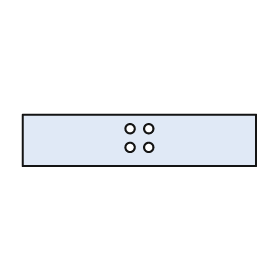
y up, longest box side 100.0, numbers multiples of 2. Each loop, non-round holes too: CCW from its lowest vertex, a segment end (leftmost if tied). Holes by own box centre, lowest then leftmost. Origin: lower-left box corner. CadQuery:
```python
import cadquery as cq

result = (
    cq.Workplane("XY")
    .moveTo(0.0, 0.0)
    .lineTo(100.0, 0.0)
    .lineTo(100.0, 22.0)
    .lineTo(0.0, 22.0)
    .close()
    .moveTo(46.0, 8.0)
    .circle(2.0)
    .moveTo(54.0, 8.0)
    .circle(2.0)
    .moveTo(46.0, 16.0)
    .circle(2.0)
    .moveTo(54.0, 16.0)
    .circle(2.0)
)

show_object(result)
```